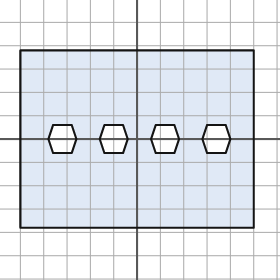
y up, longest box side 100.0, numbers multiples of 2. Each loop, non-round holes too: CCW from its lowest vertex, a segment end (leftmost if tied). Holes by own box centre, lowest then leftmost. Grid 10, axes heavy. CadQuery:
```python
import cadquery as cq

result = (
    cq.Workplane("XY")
    .moveTo(-50.0, -38.0)
    .lineTo(50.0, -38.0)
    .lineTo(50.0, 38.0)
    .lineTo(-50.0, 38.0)
    .close()
    .moveTo(-36.0, -6.0)
    .lineTo(-28.0, -6.0)
    .lineTo(-26.0, 0.0)
    .lineTo(-28.0, 6.0)
    .lineTo(-36.0, 6.0)
    .lineTo(-38.0, 0.0)
    .close()
    .moveTo(-14.0, -6.0)
    .lineTo(-6.0, -6.0)
    .lineTo(-4.0, 0.0)
    .lineTo(-6.0, 6.0)
    .lineTo(-14.0, 6.0)
    .lineTo(-16.0, 0.0)
    .close()
    .moveTo(8.0, -6.0)
    .lineTo(16.0, -6.0)
    .lineTo(18.0, 0.0)
    .lineTo(16.0, 6.0)
    .lineTo(8.0, 6.0)
    .lineTo(6.0, 0.0)
    .close()
    .moveTo(30.0, -6.0)
    .lineTo(38.0, -6.0)
    .lineTo(40.0, 0.0)
    .lineTo(38.0, 6.0)
    .lineTo(30.0, 6.0)
    .lineTo(28.0, 0.0)
    .close()
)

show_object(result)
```